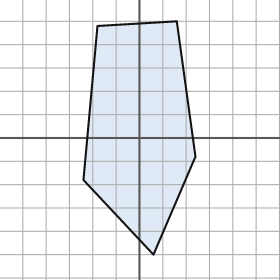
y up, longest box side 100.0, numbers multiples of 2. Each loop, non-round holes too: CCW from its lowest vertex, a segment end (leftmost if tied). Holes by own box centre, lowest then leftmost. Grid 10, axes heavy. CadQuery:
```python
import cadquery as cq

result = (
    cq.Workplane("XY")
    .moveTo(6.0, -50.0)
    .lineTo(24.0, -8.0)
    .lineTo(16.0, 50.0)
    .lineTo(-18.0, 48.0)
    .lineTo(-24.0, -18.0)
    .close()
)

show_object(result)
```